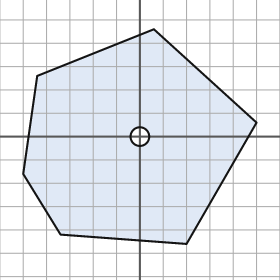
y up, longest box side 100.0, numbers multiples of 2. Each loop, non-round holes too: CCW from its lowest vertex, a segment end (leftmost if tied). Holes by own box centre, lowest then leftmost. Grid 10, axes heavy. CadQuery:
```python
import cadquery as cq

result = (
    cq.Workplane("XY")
    .moveTo(20.0, -46.0)
    .lineTo(50.0, 6.0)
    .lineTo(6.0, 46.0)
    .lineTo(-44.0, 26.0)
    .lineTo(-50.0, -16.0)
    .lineTo(-34.0, -42.0)
    .close()
    .moveTo(0.0, 0.0)
    .circle(4.0)
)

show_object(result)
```